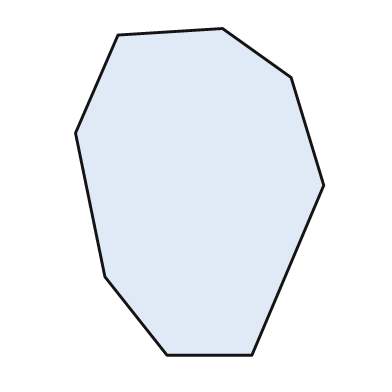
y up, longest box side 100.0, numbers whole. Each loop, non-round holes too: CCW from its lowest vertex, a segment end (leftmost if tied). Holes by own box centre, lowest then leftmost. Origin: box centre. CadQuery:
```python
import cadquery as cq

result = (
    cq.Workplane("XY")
    .moveTo(-10.0, -50.0)
    .lineTo(16.0, -50.0)
    .lineTo(38.0, 2.0)
    .lineTo(28.0, 35.0)
    .lineTo(7.0, 50.0)
    .lineTo(-25.0, 48.0)
    .lineTo(-38.0, 18.0)
    .lineTo(-29.0, -26.0)
    .close()
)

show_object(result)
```